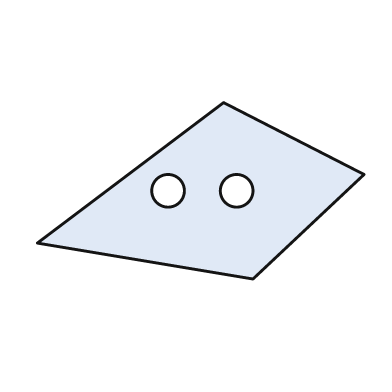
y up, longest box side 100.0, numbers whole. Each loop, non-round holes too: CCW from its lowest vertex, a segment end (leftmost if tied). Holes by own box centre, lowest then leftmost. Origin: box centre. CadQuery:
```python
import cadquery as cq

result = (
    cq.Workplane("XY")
    .moveTo(16.0, -27.0)
    .lineTo(50.0, 5.0)
    .lineTo(7.0, 27.0)
    .lineTo(-50.0, -16.0)
    .close()
    .moveTo(-10.0, 0.0)
    .circle(5.0)
    .moveTo(11.0, 0.0)
    .circle(5.0)
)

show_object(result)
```